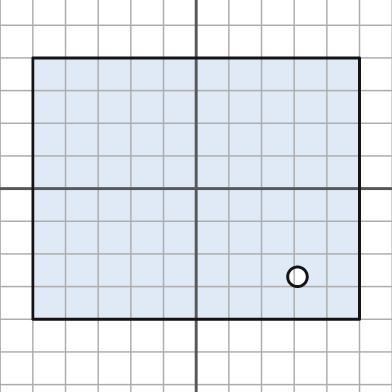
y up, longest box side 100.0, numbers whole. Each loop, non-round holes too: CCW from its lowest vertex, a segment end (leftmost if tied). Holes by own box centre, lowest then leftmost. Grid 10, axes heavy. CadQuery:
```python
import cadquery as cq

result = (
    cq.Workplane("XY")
    .moveTo(-50.0, -40.0)
    .lineTo(50.0, -40.0)
    .lineTo(50.0, 40.0)
    .lineTo(-50.0, 40.0)
    .close()
    .moveTo(31.0, -27.0)
    .circle(3.0)
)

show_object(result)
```